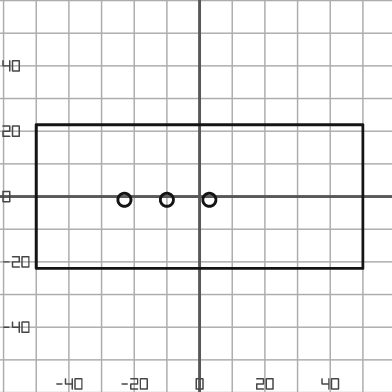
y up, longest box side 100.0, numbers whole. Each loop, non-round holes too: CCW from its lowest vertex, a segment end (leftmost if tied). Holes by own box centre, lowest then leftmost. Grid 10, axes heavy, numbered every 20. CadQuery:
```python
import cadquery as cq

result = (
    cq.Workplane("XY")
    .moveTo(-50.0, -22.0)
    .lineTo(50.0, -22.0)
    .lineTo(50.0, 22.0)
    .lineTo(-50.0, 22.0)
    .close()
    .moveTo(-23.0, -1.0)
    .circle(2.0)
    .moveTo(-10.0, -1.0)
    .circle(2.0)
    .moveTo(3.0, -1.0)
    .circle(2.0)
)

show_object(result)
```